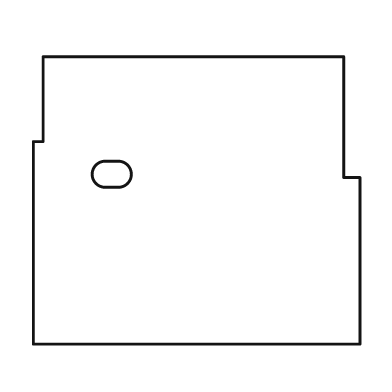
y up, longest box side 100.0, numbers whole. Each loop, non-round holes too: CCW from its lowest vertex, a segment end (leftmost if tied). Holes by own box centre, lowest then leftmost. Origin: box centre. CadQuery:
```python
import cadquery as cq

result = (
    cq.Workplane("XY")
    .moveTo(-50.0, -44.0)
    .lineTo(50.0, -44.0)
    .lineTo(50.0, 7.0)
    .lineTo(45.0, 7.0)
    .lineTo(45.0, 44.0)
    .lineTo(-47.0, 44.0)
    .lineTo(-47.0, 18.0)
    .lineTo(-50.0, 18.0)
    .close()
    .moveTo(-28.0, 4.0)
    .lineTo(-24.0, 4.0)
    .threePointArc((-20.0, 8.0), (-24.0, 12.0))
    .lineTo(-28.0, 12.0)
    .threePointArc((-32.0, 8.0), (-28.0, 4.0))
    .close()
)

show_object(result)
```